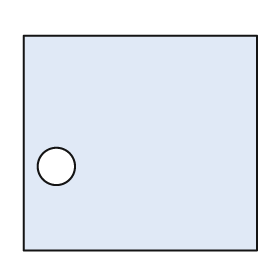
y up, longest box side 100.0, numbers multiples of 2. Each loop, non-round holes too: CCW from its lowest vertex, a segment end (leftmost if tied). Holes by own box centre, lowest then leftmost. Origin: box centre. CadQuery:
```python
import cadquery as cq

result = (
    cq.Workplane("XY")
    .moveTo(-50.0, -46.0)
    .lineTo(50.0, -46.0)
    .lineTo(50.0, 46.0)
    .lineTo(-50.0, 46.0)
    .close()
    .moveTo(-36.0, -10.0)
    .circle(8.0)
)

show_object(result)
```